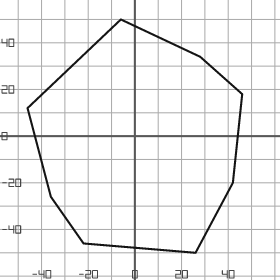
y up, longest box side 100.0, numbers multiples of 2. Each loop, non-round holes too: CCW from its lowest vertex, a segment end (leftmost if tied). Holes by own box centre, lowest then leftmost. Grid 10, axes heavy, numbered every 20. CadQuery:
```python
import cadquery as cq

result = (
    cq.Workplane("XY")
    .moveTo(26.0, -50.0)
    .lineTo(42.0, -20.0)
    .lineTo(46.0, 18.0)
    .lineTo(28.0, 34.0)
    .lineTo(-6.0, 50.0)
    .lineTo(-46.0, 12.0)
    .lineTo(-36.0, -26.0)
    .lineTo(-22.0, -46.0)
    .close()
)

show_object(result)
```